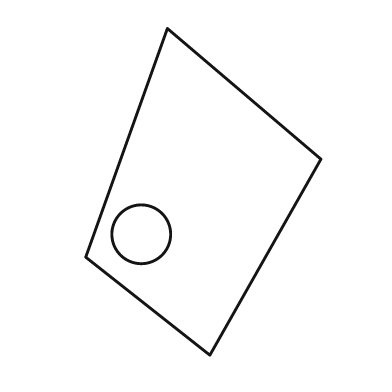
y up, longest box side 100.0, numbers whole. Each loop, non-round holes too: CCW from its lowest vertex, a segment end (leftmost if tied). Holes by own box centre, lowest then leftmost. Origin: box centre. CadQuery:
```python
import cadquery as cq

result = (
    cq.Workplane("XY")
    .moveTo(2.0, -50.0)
    .lineTo(36.0, 10.0)
    .lineTo(-11.0, 50.0)
    .lineTo(-36.0, -20.0)
    .close()
    .moveTo(-19.0, -13.0)
    .circle(9.0)
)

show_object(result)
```